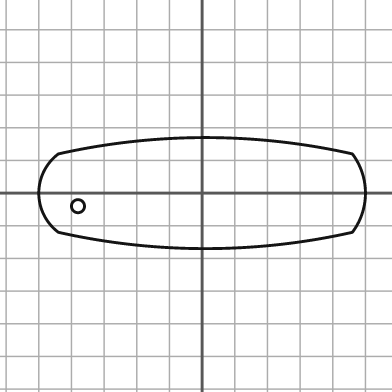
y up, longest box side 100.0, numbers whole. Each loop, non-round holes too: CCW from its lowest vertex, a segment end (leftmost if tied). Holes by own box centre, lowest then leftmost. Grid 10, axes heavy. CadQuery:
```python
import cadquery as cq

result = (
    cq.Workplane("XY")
    .moveTo(-44.0, -12.0)
    .threePointArc((1.0, -17.0), (46.0, -12.0))
    .threePointArc((50.0, 0.0), (46.0, 12.0))
    .threePointArc((1.0, 17.0), (-44.0, 12.0))
    .threePointArc((-50.0, 0.0), (-44.0, -12.0))
    .close()
    .moveTo(-38.0, -4.0)
    .circle(2.0)
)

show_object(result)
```